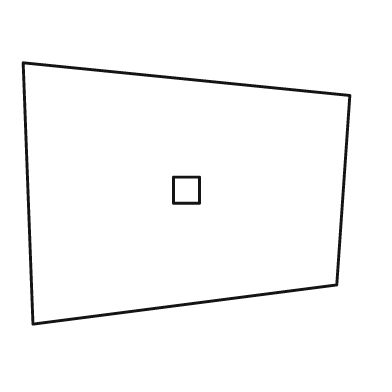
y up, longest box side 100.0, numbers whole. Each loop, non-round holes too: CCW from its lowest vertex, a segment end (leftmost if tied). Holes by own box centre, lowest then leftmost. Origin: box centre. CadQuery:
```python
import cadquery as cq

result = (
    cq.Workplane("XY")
    .moveTo(-47.0, -40.0)
    .lineTo(46.0, -28.0)
    .lineTo(50.0, 30.0)
    .lineTo(-50.0, 40.0)
    .close()
    .moveTo(-4.0, -3.0)
    .lineTo(4.0, -3.0)
    .lineTo(4.0, 5.0)
    .lineTo(-4.0, 5.0)
    .close()
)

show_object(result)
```